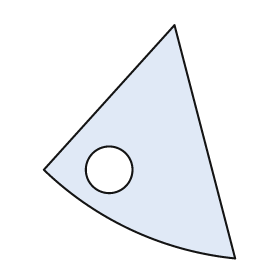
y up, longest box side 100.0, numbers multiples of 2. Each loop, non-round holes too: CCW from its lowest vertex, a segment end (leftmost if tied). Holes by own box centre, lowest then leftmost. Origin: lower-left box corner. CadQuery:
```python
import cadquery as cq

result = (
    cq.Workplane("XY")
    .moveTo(82.0, 0.0)
    .lineTo(56.0, 100.0)
    .lineTo(0.0, 38.0)
    .threePointArc((38.0, 12.0), (82.0, 0.0))
    .close()
    .moveTo(28.0, 38.0)
    .circle(10.0)
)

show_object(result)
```